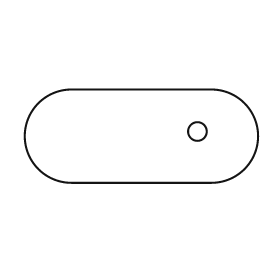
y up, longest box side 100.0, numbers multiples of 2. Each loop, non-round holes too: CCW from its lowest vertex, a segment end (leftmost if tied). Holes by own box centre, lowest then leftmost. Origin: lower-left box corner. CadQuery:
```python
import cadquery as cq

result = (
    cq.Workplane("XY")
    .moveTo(20.0, 0.0)
    .lineTo(80.0, 0.0)
    .threePointArc((100.0, 20.0), (80.0, 40.0))
    .lineTo(20.0, 40.0)
    .threePointArc((0.0, 20.0), (20.0, 0.0))
    .close()
    .moveTo(74.0, 22.0)
    .circle(4.0)
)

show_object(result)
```